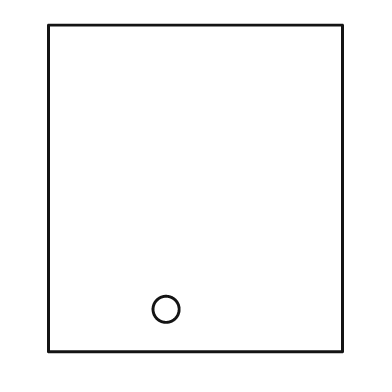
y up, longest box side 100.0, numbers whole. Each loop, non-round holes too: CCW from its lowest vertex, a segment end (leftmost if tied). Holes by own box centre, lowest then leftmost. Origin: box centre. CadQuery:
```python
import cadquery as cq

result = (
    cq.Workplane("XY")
    .moveTo(-45.0, -50.0)
    .lineTo(45.0, -50.0)
    .lineTo(45.0, 50.0)
    .lineTo(-45.0, 50.0)
    .close()
    .moveTo(-9.0, -37.0)
    .circle(4.0)
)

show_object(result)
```